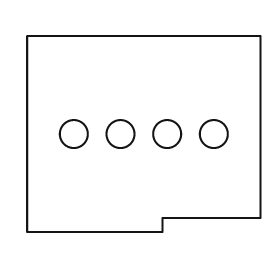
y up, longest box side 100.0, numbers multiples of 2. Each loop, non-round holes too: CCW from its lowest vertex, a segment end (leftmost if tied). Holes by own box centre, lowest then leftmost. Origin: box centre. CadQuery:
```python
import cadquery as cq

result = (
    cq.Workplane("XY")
    .moveTo(-50.0, -42.0)
    .lineTo(8.0, -42.0)
    .lineTo(8.0, -36.0)
    .lineTo(50.0, -36.0)
    .lineTo(50.0, 42.0)
    .lineTo(-50.0, 42.0)
    .close()
    .moveTo(-30.0, 0.0)
    .circle(6.0)
    .moveTo(-10.0, 0.0)
    .circle(6.0)
    .moveTo(10.0, 0.0)
    .circle(6.0)
    .moveTo(30.0, 0.0)
    .circle(6.0)
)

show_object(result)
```